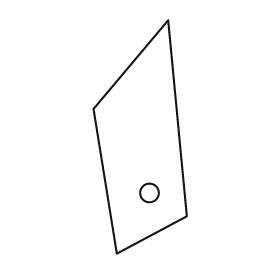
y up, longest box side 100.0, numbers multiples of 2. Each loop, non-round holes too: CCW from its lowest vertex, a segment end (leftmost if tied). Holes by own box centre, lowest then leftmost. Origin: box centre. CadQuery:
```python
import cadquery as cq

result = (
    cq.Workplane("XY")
    .moveTo(-10.0, -50.0)
    .lineTo(20.0, -34.0)
    .lineTo(12.0, 50.0)
    .lineTo(-20.0, 12.0)
    .close()
    .moveTo(4.0, -24.0)
    .circle(4.0)
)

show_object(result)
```